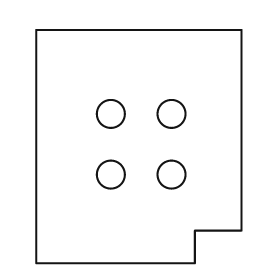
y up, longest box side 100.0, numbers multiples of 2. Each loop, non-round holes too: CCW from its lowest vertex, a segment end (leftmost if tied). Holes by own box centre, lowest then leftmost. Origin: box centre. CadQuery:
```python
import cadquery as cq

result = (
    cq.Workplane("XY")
    .moveTo(-44.0, -50.0)
    .lineTo(24.0, -50.0)
    .lineTo(24.0, -36.0)
    .lineTo(44.0, -36.0)
    .lineTo(44.0, 50.0)
    .lineTo(-44.0, 50.0)
    .close()
    .moveTo(-12.0, -12.0)
    .circle(6.0)
    .moveTo(14.0, -12.0)
    .circle(6.0)
    .moveTo(-12.0, 14.0)
    .circle(6.0)
    .moveTo(14.0, 14.0)
    .circle(6.0)
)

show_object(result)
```